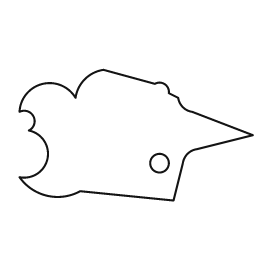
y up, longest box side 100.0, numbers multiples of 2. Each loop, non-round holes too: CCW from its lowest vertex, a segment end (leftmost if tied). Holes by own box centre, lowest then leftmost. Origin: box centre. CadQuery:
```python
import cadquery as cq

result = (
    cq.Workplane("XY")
    .moveTo(16.0, -28.0)
    .lineTo(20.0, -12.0)
    .threePointArc((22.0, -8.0), (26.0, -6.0))
    .lineTo(50.0, 0.0)
    .lineTo(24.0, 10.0)
    .threePointArc((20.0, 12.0), (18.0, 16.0))
    .lineTo(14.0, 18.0)
    .threePointArc((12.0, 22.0), (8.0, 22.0))
    .lineTo(-14.0, 28.0)
    .threePointArc((-22.0, 24.0), (-26.0, 16.0))
    .threePointArc((-40.0, 22.0), (-50.0, 10.0))
    .threePointArc((-44.0, 8.0), (-46.0, 2.0))
    .threePointArc((-38.0, -10.0), (-50.0, -18.0))
    .threePointArc((-38.0, -26.0), (-24.0, -24.0))
    .close()
    .moveTo(10.0, -12.0)
    .circle(4.0)
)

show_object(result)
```